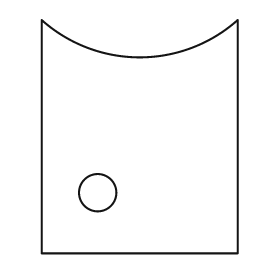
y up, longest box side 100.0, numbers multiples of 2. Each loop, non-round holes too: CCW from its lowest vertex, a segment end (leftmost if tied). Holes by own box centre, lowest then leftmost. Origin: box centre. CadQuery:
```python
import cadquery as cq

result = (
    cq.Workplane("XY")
    .moveTo(-42.0, -50.0)
    .lineTo(42.0, -50.0)
    .lineTo(42.0, 50.0)
    .threePointArc((0.0, 34.0), (-42.0, 50.0))
    .close()
    .moveTo(-18.0, -24.0)
    .circle(8.0)
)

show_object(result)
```